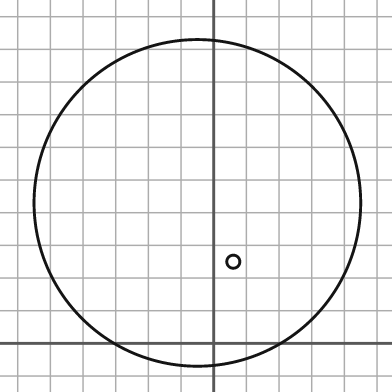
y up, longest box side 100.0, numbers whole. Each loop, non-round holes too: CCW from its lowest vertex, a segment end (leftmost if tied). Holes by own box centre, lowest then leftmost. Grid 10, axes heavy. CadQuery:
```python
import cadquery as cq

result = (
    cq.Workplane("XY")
    .moveTo(-5.0, 43.0)
    .circle(50.0)
    .moveTo(6.0, 25.0)
    .circle(2.0)
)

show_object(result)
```